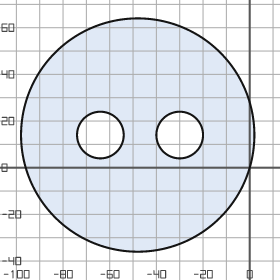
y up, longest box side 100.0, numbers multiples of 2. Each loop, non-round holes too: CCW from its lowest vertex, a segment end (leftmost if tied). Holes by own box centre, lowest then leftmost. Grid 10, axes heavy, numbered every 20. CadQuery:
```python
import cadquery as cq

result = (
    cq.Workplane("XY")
    .moveTo(-48.0, 14.0)
    .circle(50.0)
    .moveTo(-64.0, 14.0)
    .circle(10.0)
    .moveTo(-30.0, 14.0)
    .circle(10.0)
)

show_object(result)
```